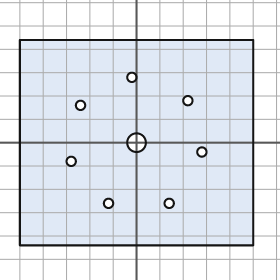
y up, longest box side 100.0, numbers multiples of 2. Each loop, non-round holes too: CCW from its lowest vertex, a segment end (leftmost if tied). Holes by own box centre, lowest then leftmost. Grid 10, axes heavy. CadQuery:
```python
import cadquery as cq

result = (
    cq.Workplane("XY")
    .moveTo(-50.0, -44.0)
    .lineTo(50.0, -44.0)
    .lineTo(50.0, 44.0)
    .lineTo(-50.0, 44.0)
    .close()
    .moveTo(-12.0, -26.0)
    .circle(2.0)
    .moveTo(14.0, -26.0)
    .circle(2.0)
    .moveTo(-28.0, -8.0)
    .circle(2.0)
    .moveTo(28.0, -4.0)
    .circle(2.0)
    .moveTo(0.0, 0.0)
    .circle(4.0)
    .moveTo(-24.0, 16.0)
    .circle(2.0)
    .moveTo(22.0, 18.0)
    .circle(2.0)
    .moveTo(-2.0, 28.0)
    .circle(2.0)
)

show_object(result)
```